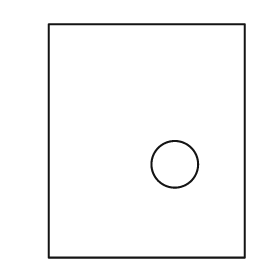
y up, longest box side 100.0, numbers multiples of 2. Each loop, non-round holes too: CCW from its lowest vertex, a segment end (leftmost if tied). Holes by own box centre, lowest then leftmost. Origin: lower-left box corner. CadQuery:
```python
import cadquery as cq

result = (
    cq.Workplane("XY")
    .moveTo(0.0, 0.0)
    .lineTo(84.0, 0.0)
    .lineTo(84.0, 100.0)
    .lineTo(0.0, 100.0)
    .close()
    .moveTo(54.0, 40.0)
    .circle(10.0)
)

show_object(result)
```